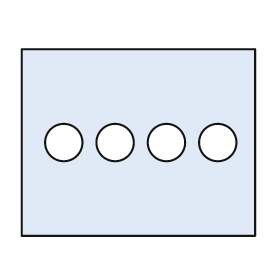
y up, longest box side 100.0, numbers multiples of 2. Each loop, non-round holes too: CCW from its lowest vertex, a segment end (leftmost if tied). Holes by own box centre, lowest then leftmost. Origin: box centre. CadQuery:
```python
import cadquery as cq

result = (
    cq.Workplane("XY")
    .moveTo(-50.0, -40.0)
    .lineTo(50.0, -40.0)
    .lineTo(50.0, 40.0)
    .lineTo(-50.0, 40.0)
    .close()
    .moveTo(-32.0, 0.0)
    .circle(8.0)
    .moveTo(-10.0, 0.0)
    .circle(8.0)
    .moveTo(12.0, 0.0)
    .circle(8.0)
    .moveTo(34.0, 0.0)
    .circle(8.0)
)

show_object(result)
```